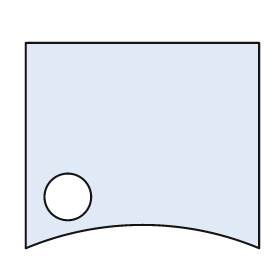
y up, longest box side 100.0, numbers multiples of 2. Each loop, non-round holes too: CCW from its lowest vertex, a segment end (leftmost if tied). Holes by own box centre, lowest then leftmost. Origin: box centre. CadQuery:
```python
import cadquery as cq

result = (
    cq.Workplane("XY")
    .moveTo(-50.0, -44.0)
    .threePointArc((0.0, -34.0), (50.0, -44.0))
    .lineTo(50.0, 44.0)
    .lineTo(-50.0, 44.0)
    .close()
    .moveTo(-32.0, -22.0)
    .circle(10.0)
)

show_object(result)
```